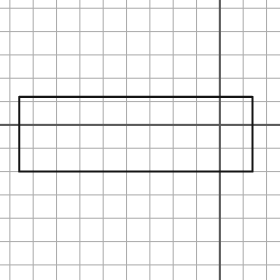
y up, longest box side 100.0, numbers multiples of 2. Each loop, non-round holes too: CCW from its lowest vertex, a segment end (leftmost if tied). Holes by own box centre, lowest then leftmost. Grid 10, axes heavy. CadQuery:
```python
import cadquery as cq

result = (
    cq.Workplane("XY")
    .moveTo(-86.0, -20.0)
    .lineTo(14.0, -20.0)
    .lineTo(14.0, 12.0)
    .lineTo(-86.0, 12.0)
    .close()
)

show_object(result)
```